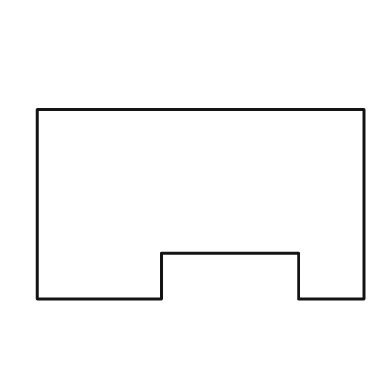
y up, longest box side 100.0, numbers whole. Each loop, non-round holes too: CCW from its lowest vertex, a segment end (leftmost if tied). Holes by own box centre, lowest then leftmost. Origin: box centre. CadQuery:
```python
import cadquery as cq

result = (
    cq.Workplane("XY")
    .moveTo(-50.0, -29.0)
    .lineTo(-12.0, -29.0)
    .lineTo(-12.0, -15.0)
    .lineTo(30.0, -15.0)
    .lineTo(30.0, -29.0)
    .lineTo(50.0, -29.0)
    .lineTo(50.0, 29.0)
    .lineTo(-50.0, 29.0)
    .close()
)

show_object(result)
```